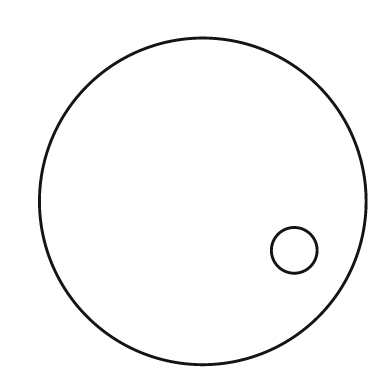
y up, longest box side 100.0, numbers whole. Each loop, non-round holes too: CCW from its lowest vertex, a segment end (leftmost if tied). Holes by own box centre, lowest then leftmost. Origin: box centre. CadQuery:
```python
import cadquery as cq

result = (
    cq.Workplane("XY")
    .moveTo(0.0, 0.0)
    .circle(50.0)
    .moveTo(28.0, -15.0)
    .circle(7.0)
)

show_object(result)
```